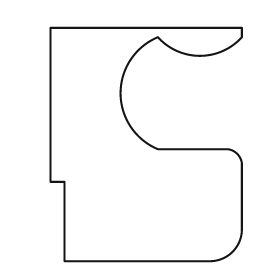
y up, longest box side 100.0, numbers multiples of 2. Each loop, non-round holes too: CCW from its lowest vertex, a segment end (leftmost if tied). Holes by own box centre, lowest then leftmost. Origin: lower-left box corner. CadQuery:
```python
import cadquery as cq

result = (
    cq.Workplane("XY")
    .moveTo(6.0, 0.0)
    .lineTo(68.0, 0.0)
    .threePointArc((78.0, 4.0), (82.0, 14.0))
    .lineTo(82.0, 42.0)
    .threePointArc((80.0, 46.0), (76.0, 48.0))
    .lineTo(46.0, 48.0)
    .threePointArc((30.0, 72.0), (46.0, 96.0))
    .threePointArc((64.0, 88.0), (82.0, 96.0))
    .lineTo(82.0, 100.0)
    .lineTo(0.0, 100.0)
    .lineTo(0.0, 34.0)
    .lineTo(6.0, 34.0)
    .close()
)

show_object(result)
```